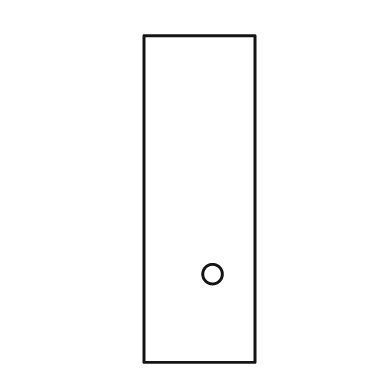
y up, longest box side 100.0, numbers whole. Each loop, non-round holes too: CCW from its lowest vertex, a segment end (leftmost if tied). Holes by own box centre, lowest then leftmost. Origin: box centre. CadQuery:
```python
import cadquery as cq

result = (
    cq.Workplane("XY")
    .moveTo(-17.0, -50.0)
    .lineTo(17.0, -50.0)
    .lineTo(17.0, 50.0)
    .lineTo(-17.0, 50.0)
    .close()
    .moveTo(4.0, -23.0)
    .circle(3.0)
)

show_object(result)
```